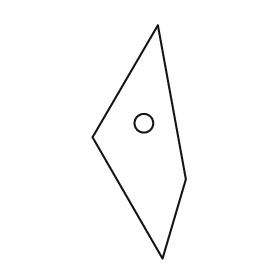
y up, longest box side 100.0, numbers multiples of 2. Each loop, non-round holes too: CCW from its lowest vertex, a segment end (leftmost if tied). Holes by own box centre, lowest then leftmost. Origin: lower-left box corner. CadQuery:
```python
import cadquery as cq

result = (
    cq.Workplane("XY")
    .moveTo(30.0, 0.0)
    .lineTo(40.0, 34.0)
    .lineTo(28.0, 100.0)
    .lineTo(0.0, 52.0)
    .close()
    .moveTo(22.0, 58.0)
    .circle(4.0)
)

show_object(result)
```